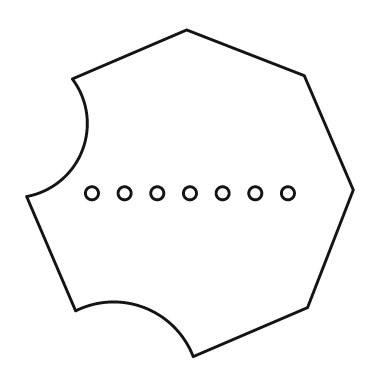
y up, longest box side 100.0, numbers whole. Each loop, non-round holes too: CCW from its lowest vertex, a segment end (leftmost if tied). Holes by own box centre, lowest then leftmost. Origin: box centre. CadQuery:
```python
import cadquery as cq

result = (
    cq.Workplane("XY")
    .moveTo(1.0, -50.0)
    .lineTo(36.0, -35.0)
    .lineTo(50.0, 1.0)
    .lineTo(35.0, 36.0)
    .lineTo(-1.0, 50.0)
    .lineTo(-36.0, 35.0)
    .threePointArc((-33.0, 13.0), (-50.0, -1.0))
    .lineTo(-35.0, -36.0)
    .threePointArc((-14.0, -35.0), (1.0, -50.0))
    .close()
    .moveTo(-30.0, 0.0)
    .circle(2.0)
    .moveTo(-20.0, 0.0)
    .circle(2.0)
    .moveTo(-10.0, 0.0)
    .circle(2.0)
    .moveTo(0.0, 0.0)
    .circle(2.0)
    .moveTo(10.0, 0.0)
    .circle(2.0)
    .moveTo(20.0, 0.0)
    .circle(2.0)
    .moveTo(30.0, 0.0)
    .circle(2.0)
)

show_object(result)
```